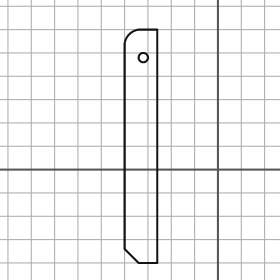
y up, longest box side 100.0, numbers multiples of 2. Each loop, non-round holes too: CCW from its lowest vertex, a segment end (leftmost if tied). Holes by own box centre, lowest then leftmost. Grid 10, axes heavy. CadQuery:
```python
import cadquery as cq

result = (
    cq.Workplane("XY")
    .moveTo(-34.0, -40.0)
    .lineTo(-26.0, -40.0)
    .lineTo(-26.0, 60.0)
    .lineTo(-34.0, 60.0)
    .threePointArc((-38.0, 58.0), (-40.0, 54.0))
    .lineTo(-40.0, -34.0)
    .close()
    .moveTo(-32.0, 48.0)
    .circle(2.0)
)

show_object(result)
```